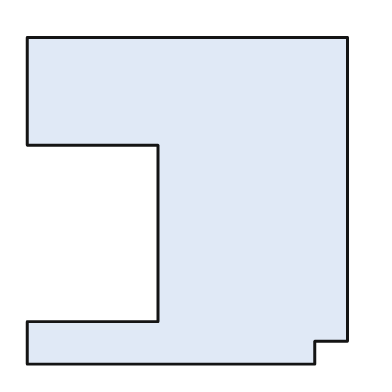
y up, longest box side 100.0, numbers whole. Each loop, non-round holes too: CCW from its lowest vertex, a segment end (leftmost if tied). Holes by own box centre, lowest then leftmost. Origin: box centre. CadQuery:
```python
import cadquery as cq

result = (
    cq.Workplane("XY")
    .moveTo(-49.0, -50.0)
    .lineTo(39.0, -50.0)
    .lineTo(39.0, -43.0)
    .lineTo(49.0, -43.0)
    .lineTo(49.0, 50.0)
    .lineTo(-49.0, 50.0)
    .lineTo(-49.0, 17.0)
    .lineTo(-9.0, 17.0)
    .lineTo(-9.0, -37.0)
    .lineTo(-49.0, -37.0)
    .close()
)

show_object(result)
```